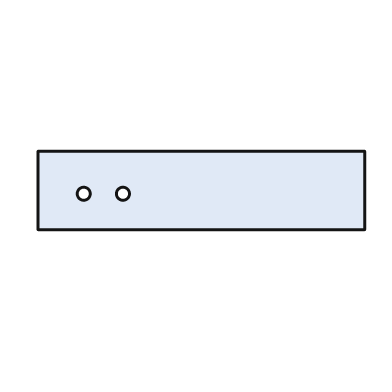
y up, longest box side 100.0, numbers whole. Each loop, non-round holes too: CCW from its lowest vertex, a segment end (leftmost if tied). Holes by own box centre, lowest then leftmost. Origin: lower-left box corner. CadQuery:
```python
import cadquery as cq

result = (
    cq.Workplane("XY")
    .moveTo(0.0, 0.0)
    .lineTo(100.0, 0.0)
    .lineTo(100.0, 24.0)
    .lineTo(0.0, 24.0)
    .close()
    .moveTo(14.0, 11.0)
    .circle(2.0)
    .moveTo(26.0, 11.0)
    .circle(2.0)
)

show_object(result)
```